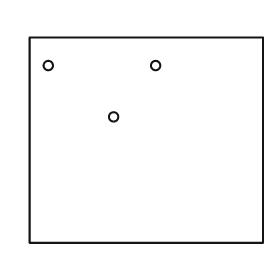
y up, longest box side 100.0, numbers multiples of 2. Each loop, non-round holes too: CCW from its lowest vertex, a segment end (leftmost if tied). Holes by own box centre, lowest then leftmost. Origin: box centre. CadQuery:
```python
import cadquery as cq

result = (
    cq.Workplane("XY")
    .moveTo(-50.0, -44.0)
    .lineTo(50.0, -44.0)
    .lineTo(50.0, 44.0)
    .lineTo(-50.0, 44.0)
    .close()
    .moveTo(-14.0, 10.0)
    .circle(2.0)
    .moveTo(-42.0, 32.0)
    .circle(2.0)
    .moveTo(4.0, 32.0)
    .circle(2.0)
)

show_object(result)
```